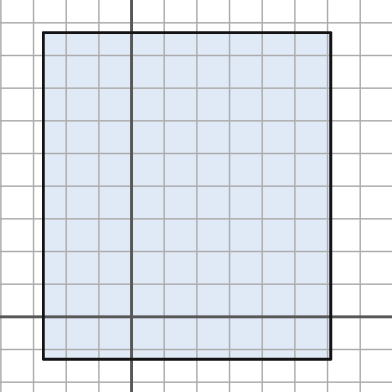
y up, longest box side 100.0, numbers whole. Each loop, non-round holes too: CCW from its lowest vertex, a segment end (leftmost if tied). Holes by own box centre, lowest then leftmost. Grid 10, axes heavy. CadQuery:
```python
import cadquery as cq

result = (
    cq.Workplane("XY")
    .moveTo(-27.0, -13.0)
    .lineTo(61.0, -13.0)
    .lineTo(61.0, 87.0)
    .lineTo(-27.0, 87.0)
    .close()
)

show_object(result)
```